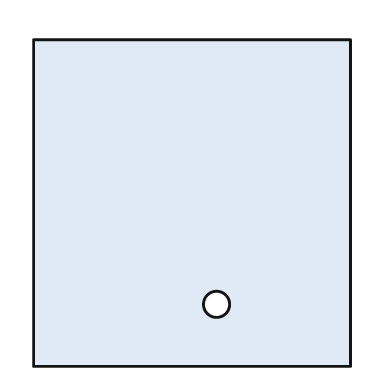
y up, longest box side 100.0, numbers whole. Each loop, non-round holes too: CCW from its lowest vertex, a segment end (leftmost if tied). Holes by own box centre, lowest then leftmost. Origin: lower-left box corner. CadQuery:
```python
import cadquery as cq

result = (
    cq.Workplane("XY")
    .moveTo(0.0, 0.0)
    .lineTo(97.0, 0.0)
    .lineTo(97.0, 100.0)
    .lineTo(0.0, 100.0)
    .close()
    .moveTo(56.0, 19.0)
    .circle(4.0)
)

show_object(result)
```